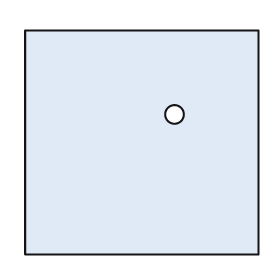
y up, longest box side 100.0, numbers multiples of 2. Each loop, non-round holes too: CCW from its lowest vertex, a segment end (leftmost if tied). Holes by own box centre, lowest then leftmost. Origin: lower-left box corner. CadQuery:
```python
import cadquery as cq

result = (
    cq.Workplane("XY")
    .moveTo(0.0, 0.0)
    .lineTo(100.0, 0.0)
    .lineTo(100.0, 96.0)
    .lineTo(0.0, 96.0)
    .close()
    .moveTo(64.0, 60.0)
    .circle(4.0)
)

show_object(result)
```